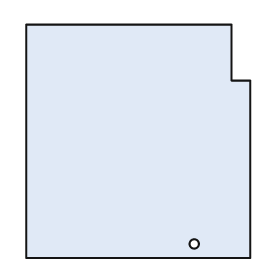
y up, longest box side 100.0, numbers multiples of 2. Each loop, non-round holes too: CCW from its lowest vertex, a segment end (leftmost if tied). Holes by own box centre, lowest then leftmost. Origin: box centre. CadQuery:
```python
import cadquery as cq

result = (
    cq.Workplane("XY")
    .moveTo(-48.0, -50.0)
    .lineTo(48.0, -50.0)
    .lineTo(48.0, 26.0)
    .lineTo(40.0, 26.0)
    .lineTo(40.0, 50.0)
    .lineTo(-48.0, 50.0)
    .close()
    .moveTo(24.0, -44.0)
    .circle(2.0)
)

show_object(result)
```